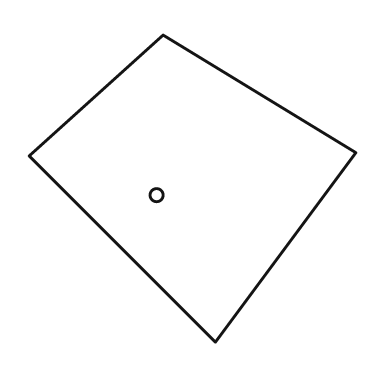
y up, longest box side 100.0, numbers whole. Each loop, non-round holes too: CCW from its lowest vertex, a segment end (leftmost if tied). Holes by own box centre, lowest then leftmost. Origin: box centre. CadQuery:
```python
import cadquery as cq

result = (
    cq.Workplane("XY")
    .moveTo(7.0, -47.0)
    .lineTo(50.0, 11.0)
    .lineTo(-9.0, 47.0)
    .lineTo(-50.0, 10.0)
    .close()
    .moveTo(-11.0, -2.0)
    .circle(2.0)
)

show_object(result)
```